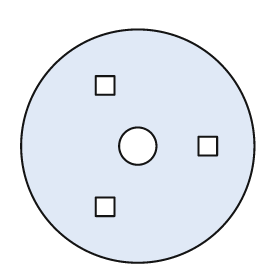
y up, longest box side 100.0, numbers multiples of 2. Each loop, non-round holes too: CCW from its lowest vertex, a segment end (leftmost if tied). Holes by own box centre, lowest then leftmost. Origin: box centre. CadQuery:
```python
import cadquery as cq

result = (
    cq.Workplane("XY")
    .moveTo(0.0, 0.0)
    .circle(50.0)
    .moveTo(-18.0, -30.0)
    .lineTo(-10.0, -30.0)
    .lineTo(-10.0, -22.0)
    .lineTo(-18.0, -22.0)
    .close()
    .moveTo(0.0, 0.0)
    .circle(8.0)
    .moveTo(26.0, -4.0)
    .lineTo(34.0, -4.0)
    .lineTo(34.0, 4.0)
    .lineTo(26.0, 4.0)
    .close()
    .moveTo(-18.0, 22.0)
    .lineTo(-10.0, 22.0)
    .lineTo(-10.0, 30.0)
    .lineTo(-18.0, 30.0)
    .close()
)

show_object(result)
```